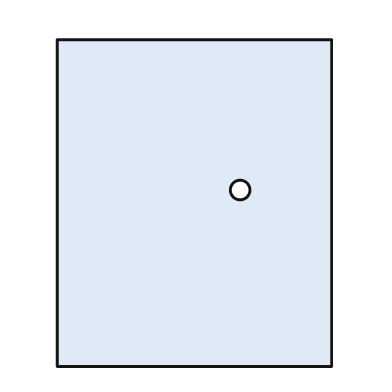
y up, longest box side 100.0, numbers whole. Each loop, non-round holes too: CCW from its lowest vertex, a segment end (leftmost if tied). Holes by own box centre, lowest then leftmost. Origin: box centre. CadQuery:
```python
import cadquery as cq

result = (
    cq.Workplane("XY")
    .moveTo(-42.0, -50.0)
    .lineTo(42.0, -50.0)
    .lineTo(42.0, 50.0)
    .lineTo(-42.0, 50.0)
    .close()
    .moveTo(14.0, 4.0)
    .circle(3.0)
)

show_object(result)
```